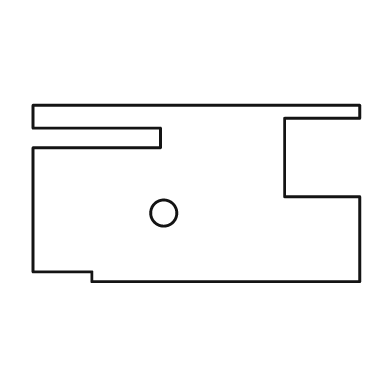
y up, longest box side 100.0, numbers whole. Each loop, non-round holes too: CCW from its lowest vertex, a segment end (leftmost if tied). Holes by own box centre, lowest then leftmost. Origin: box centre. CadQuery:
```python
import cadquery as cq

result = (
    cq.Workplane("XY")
    .moveTo(-32.0, -27.0)
    .lineTo(50.0, -27.0)
    .lineTo(50.0, -1.0)
    .lineTo(27.0, -1.0)
    .lineTo(27.0, 23.0)
    .lineTo(50.0, 23.0)
    .lineTo(50.0, 27.0)
    .lineTo(-50.0, 27.0)
    .lineTo(-50.0, 20.0)
    .lineTo(-11.0, 20.0)
    .lineTo(-11.0, 14.0)
    .lineTo(-50.0, 14.0)
    .lineTo(-50.0, -24.0)
    .lineTo(-32.0, -24.0)
    .close()
    .moveTo(-10.0, -6.0)
    .circle(4.0)
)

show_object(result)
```